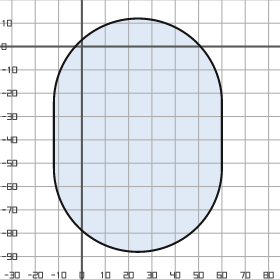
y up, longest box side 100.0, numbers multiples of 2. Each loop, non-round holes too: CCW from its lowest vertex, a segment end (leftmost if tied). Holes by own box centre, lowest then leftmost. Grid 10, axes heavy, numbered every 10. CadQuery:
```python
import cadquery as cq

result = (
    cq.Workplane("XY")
    .moveTo(-12.0, -52.0)
    .threePointArc((24.0, -88.0), (60.0, -52.0))
    .lineTo(60.0, -24.0)
    .threePointArc((24.0, 12.0), (-12.0, -24.0))
    .close()
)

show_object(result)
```